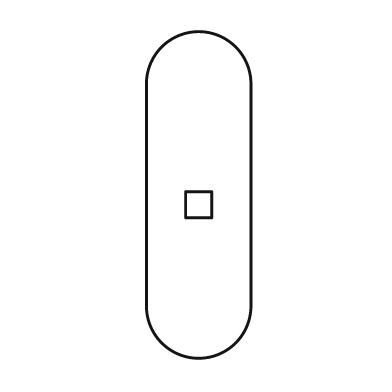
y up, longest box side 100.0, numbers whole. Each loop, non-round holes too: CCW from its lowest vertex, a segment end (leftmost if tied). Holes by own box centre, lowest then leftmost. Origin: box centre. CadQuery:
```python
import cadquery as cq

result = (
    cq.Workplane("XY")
    .moveTo(-16.0, -34.0)
    .threePointArc((0.0, -50.0), (16.0, -34.0))
    .lineTo(16.0, 34.0)
    .threePointArc((0.0, 50.0), (-16.0, 34.0))
    .close()
    .moveTo(-4.0, -7.0)
    .lineTo(4.0, -7.0)
    .lineTo(4.0, 1.0)
    .lineTo(-4.0, 1.0)
    .close()
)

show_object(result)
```